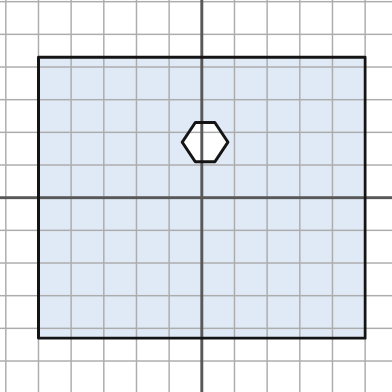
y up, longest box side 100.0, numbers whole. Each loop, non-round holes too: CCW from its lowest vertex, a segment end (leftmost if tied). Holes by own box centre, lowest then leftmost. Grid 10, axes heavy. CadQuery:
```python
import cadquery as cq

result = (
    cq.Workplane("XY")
    .moveTo(-50.0, -43.0)
    .lineTo(50.0, -43.0)
    .lineTo(50.0, 43.0)
    .lineTo(-50.0, 43.0)
    .close()
    .moveTo(-2.0, 11.0)
    .lineTo(4.0, 11.0)
    .lineTo(8.0, 17.0)
    .lineTo(4.0, 23.0)
    .lineTo(-2.0, 23.0)
    .lineTo(-6.0, 17.0)
    .close()
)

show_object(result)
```